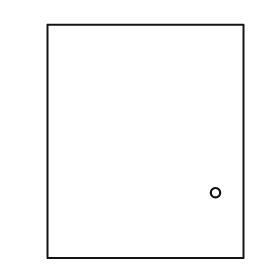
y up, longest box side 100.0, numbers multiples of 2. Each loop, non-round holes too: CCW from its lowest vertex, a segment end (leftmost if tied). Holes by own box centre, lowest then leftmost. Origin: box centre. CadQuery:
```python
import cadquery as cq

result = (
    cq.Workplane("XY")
    .moveTo(-42.0, -50.0)
    .lineTo(42.0, -50.0)
    .lineTo(42.0, 50.0)
    .lineTo(-42.0, 50.0)
    .close()
    .moveTo(30.0, -22.0)
    .circle(2.0)
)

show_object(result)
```